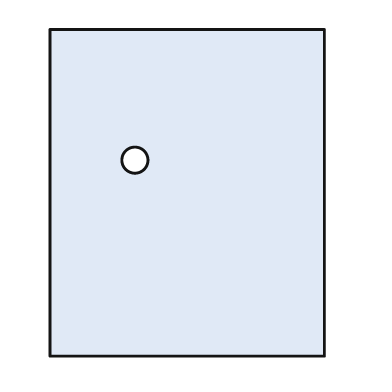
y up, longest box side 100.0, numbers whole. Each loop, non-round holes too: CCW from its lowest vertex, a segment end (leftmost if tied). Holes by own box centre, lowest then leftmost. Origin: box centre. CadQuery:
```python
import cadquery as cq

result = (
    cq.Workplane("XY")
    .moveTo(-42.0, -50.0)
    .lineTo(42.0, -50.0)
    .lineTo(42.0, 50.0)
    .lineTo(-42.0, 50.0)
    .close()
    .moveTo(-16.0, 10.0)
    .circle(4.0)
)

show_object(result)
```